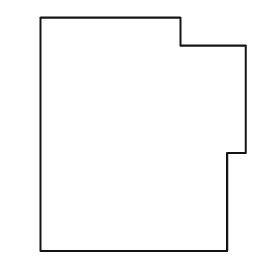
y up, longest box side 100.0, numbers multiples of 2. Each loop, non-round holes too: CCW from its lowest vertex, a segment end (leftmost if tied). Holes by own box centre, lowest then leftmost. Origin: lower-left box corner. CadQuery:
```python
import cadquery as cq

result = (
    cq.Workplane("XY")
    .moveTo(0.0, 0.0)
    .lineTo(80.0, 0.0)
    .lineTo(80.0, 42.0)
    .lineTo(88.0, 42.0)
    .lineTo(88.0, 88.0)
    .lineTo(60.0, 88.0)
    .lineTo(60.0, 100.0)
    .lineTo(0.0, 100.0)
    .close()
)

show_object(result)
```